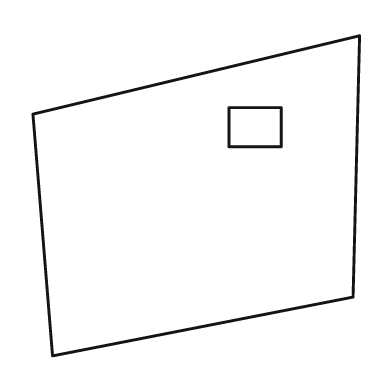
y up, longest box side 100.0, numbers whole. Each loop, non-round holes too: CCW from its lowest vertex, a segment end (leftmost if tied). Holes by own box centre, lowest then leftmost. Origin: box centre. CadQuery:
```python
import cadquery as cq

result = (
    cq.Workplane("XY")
    .moveTo(-44.0, -49.0)
    .lineTo(48.0, -31.0)
    .lineTo(50.0, 49.0)
    .lineTo(-50.0, 25.0)
    .close()
    .moveTo(10.0, 15.0)
    .lineTo(26.0, 15.0)
    .lineTo(26.0, 27.0)
    .lineTo(10.0, 27.0)
    .close()
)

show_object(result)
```